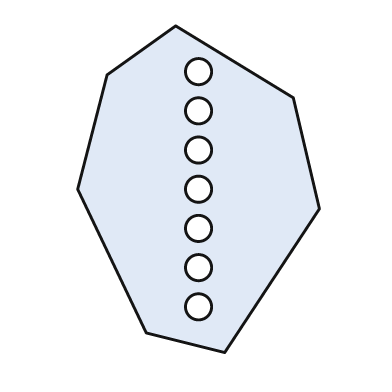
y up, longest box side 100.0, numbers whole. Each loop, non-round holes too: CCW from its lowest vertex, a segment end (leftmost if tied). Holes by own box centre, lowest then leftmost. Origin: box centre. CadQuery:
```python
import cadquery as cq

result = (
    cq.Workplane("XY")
    .moveTo(8.0, -50.0)
    .lineTo(37.0, -6.0)
    .lineTo(29.0, 28.0)
    .lineTo(-7.0, 50.0)
    .lineTo(-28.0, 35.0)
    .lineTo(-37.0, 0.0)
    .lineTo(-16.0, -44.0)
    .close()
    .moveTo(0.0, -36.0)
    .circle(4.0)
    .moveTo(0.0, -24.0)
    .circle(4.0)
    .moveTo(0.0, -12.0)
    .circle(4.0)
    .moveTo(0.0, 0.0)
    .circle(4.0)
    .moveTo(0.0, 12.0)
    .circle(4.0)
    .moveTo(0.0, 24.0)
    .circle(4.0)
    .moveTo(0.0, 36.0)
    .circle(4.0)
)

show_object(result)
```